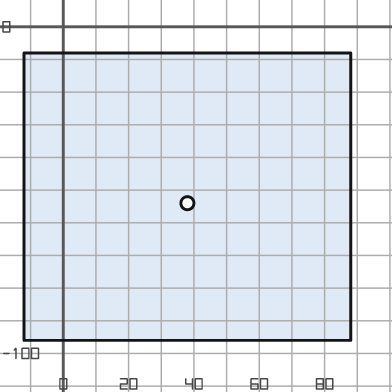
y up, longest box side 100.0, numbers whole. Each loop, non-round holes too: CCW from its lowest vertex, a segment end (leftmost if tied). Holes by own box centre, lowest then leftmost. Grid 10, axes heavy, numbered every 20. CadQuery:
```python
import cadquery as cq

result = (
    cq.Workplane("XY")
    .moveTo(-12.0, -96.0)
    .lineTo(88.0, -96.0)
    .lineTo(88.0, -8.0)
    .lineTo(-12.0, -8.0)
    .close()
    .moveTo(38.0, -54.0)
    .circle(2.0)
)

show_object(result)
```